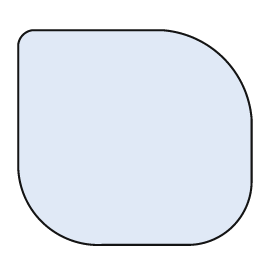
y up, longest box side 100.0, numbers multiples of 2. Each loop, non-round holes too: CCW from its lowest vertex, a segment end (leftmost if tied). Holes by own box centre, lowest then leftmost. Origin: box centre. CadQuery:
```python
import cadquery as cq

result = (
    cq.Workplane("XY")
    .moveTo(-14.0, -46.0)
    .lineTo(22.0, -46.0)
    .threePointArc((42.0, -38.0), (50.0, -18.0))
    .lineTo(50.0, 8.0)
    .threePointArc((38.0, 34.0), (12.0, 46.0))
    .lineTo(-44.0, 46.0)
    .threePointArc((-48.0, 44.0), (-50.0, 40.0))
    .lineTo(-50.0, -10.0)
    .threePointArc((-40.0, -36.0), (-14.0, -46.0))
    .close()
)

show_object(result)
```